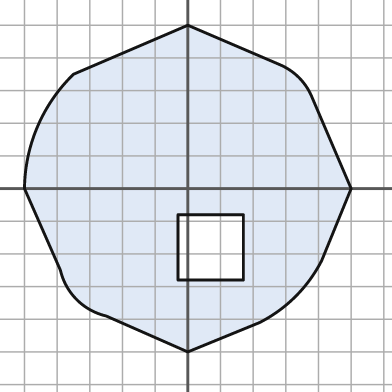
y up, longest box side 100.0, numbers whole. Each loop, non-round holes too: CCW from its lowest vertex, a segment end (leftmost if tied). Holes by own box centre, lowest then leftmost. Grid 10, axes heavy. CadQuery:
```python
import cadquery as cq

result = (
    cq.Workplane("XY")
    .moveTo(0.0, -50.0)
    .lineTo(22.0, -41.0)
    .threePointArc((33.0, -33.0), (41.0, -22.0))
    .lineTo(50.0, 0.0)
    .lineTo(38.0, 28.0)
    .threePointArc((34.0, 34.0), (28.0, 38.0))
    .lineTo(0.0, 50.0)
    .lineTo(-35.0, 35.0)
    .threePointArc((-46.0, 19.0), (-50.0, 0.0))
    .lineTo(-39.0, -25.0)
    .threePointArc((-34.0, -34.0), (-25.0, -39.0))
    .close()
    .moveTo(-3.0, -28.0)
    .lineTo(17.0, -28.0)
    .lineTo(17.0, -8.0)
    .lineTo(-3.0, -8.0)
    .close()
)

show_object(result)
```